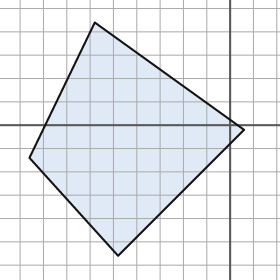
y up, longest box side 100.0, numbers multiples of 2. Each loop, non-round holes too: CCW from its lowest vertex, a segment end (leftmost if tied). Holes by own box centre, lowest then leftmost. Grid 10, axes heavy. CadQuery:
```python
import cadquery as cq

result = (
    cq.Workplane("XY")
    .moveTo(-48.0, -56.0)
    .lineTo(6.0, -2.0)
    .lineTo(-58.0, 44.0)
    .lineTo(-86.0, -14.0)
    .close()
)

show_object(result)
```